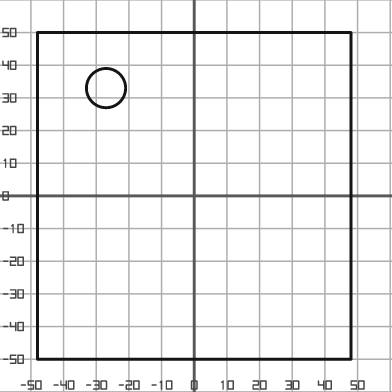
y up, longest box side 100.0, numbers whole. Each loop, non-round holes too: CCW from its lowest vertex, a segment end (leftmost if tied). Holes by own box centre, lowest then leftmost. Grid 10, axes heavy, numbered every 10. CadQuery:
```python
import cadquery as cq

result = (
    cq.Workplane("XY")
    .moveTo(-48.0, -50.0)
    .lineTo(48.0, -50.0)
    .lineTo(48.0, 50.0)
    .lineTo(-48.0, 50.0)
    .close()
    .moveTo(-27.0, 33.0)
    .circle(6.0)
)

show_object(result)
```